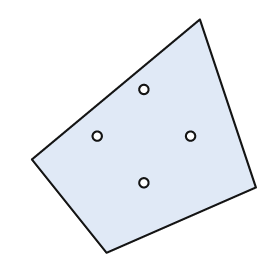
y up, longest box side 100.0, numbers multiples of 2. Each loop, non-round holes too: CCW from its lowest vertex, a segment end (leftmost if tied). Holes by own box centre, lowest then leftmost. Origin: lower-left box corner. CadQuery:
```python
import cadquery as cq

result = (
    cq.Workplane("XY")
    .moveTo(32.0, 0.0)
    .lineTo(96.0, 28.0)
    .lineTo(72.0, 100.0)
    .lineTo(0.0, 40.0)
    .close()
    .moveTo(48.0, 30.0)
    .circle(2.0)
    .moveTo(28.0, 50.0)
    .circle(2.0)
    .moveTo(68.0, 50.0)
    .circle(2.0)
    .moveTo(48.0, 70.0)
    .circle(2.0)
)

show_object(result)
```